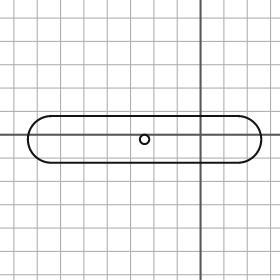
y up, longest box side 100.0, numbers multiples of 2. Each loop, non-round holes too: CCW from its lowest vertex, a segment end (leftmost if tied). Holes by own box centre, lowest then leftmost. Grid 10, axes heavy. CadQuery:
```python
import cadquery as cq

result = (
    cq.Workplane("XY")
    .moveTo(-64.0, -12.0)
    .lineTo(16.0, -12.0)
    .threePointArc((26.0, -2.0), (16.0, 8.0))
    .lineTo(-64.0, 8.0)
    .threePointArc((-74.0, -2.0), (-64.0, -12.0))
    .close()
    .moveTo(-24.0, -2.0)
    .circle(2.0)
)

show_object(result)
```